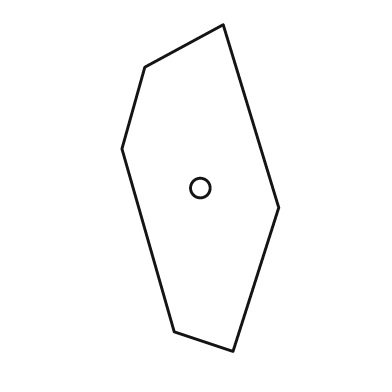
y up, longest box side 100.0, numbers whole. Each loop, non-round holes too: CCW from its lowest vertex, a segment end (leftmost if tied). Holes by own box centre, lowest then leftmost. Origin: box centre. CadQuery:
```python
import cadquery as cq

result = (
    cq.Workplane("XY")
    .moveTo(10.0, -50.0)
    .lineTo(24.0, -6.0)
    .lineTo(7.0, 50.0)
    .lineTo(-17.0, 37.0)
    .lineTo(-24.0, 12.0)
    .lineTo(-8.0, -44.0)
    .close()
    .moveTo(0.0, 0.0)
    .circle(3.0)
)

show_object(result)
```